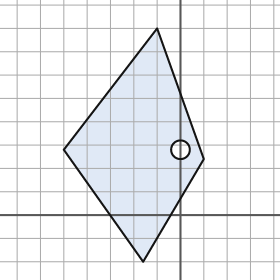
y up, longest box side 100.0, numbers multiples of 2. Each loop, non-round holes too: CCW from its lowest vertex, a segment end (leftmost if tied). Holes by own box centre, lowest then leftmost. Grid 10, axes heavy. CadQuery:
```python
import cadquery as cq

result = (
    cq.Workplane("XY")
    .moveTo(-16.0, -20.0)
    .lineTo(10.0, 24.0)
    .lineTo(-10.0, 80.0)
    .lineTo(-50.0, 28.0)
    .close()
    .moveTo(0.0, 28.0)
    .circle(4.0)
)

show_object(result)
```